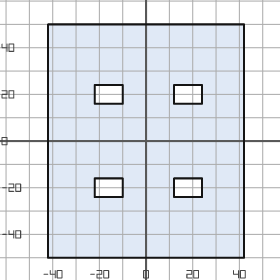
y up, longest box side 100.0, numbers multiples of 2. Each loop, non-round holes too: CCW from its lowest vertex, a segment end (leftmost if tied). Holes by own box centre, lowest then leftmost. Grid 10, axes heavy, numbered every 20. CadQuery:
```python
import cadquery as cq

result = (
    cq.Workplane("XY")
    .moveTo(-42.0, -50.0)
    .lineTo(42.0, -50.0)
    .lineTo(42.0, 50.0)
    .lineTo(-42.0, 50.0)
    .close()
    .moveTo(-22.0, -24.0)
    .lineTo(-10.0, -24.0)
    .lineTo(-10.0, -16.0)
    .lineTo(-22.0, -16.0)
    .close()
    .moveTo(12.0, -24.0)
    .lineTo(24.0, -24.0)
    .lineTo(24.0, -16.0)
    .lineTo(12.0, -16.0)
    .close()
    .moveTo(-22.0, 16.0)
    .lineTo(-10.0, 16.0)
    .lineTo(-10.0, 24.0)
    .lineTo(-22.0, 24.0)
    .close()
    .moveTo(12.0, 16.0)
    .lineTo(24.0, 16.0)
    .lineTo(24.0, 24.0)
    .lineTo(12.0, 24.0)
    .close()
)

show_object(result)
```